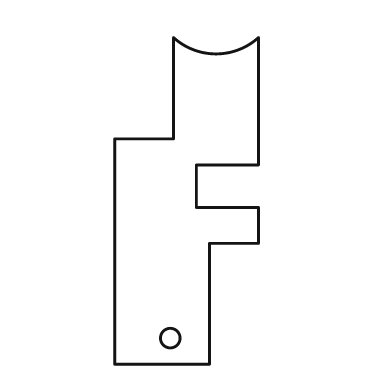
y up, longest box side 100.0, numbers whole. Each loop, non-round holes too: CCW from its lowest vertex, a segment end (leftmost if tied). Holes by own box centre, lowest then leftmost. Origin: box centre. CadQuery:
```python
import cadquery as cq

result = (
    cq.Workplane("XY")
    .moveTo(-22.0, -50.0)
    .lineTo(7.0, -50.0)
    .lineTo(7.0, -13.0)
    .lineTo(22.0, -13.0)
    .lineTo(22.0, -2.0)
    .lineTo(3.0, -2.0)
    .lineTo(3.0, 11.0)
    .lineTo(22.0, 11.0)
    .lineTo(22.0, 50.0)
    .threePointArc((9.0, 45.0), (-4.0, 50.0))
    .lineTo(-4.0, 19.0)
    .lineTo(-22.0, 19.0)
    .close()
    .moveTo(-5.0, -42.0)
    .circle(3.0)
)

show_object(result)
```